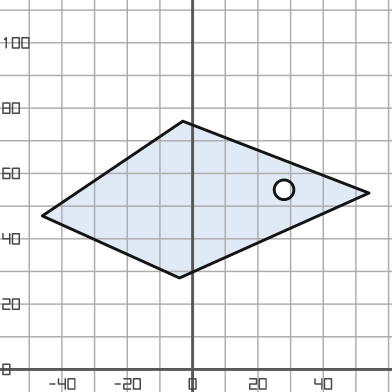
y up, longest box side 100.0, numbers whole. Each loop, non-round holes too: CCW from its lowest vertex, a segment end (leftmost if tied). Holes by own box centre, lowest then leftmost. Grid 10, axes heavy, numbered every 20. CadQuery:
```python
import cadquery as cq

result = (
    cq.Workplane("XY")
    .moveTo(-4.0, 28.0)
    .lineTo(54.0, 54.0)
    .lineTo(-3.0, 76.0)
    .lineTo(-46.0, 47.0)
    .close()
    .moveTo(28.0, 55.0)
    .circle(3.0)
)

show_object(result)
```